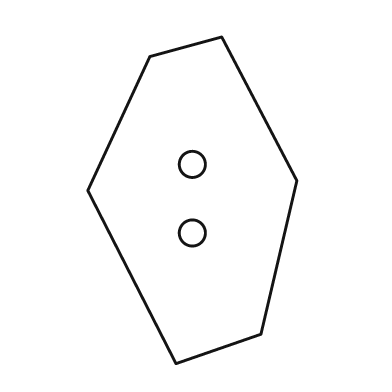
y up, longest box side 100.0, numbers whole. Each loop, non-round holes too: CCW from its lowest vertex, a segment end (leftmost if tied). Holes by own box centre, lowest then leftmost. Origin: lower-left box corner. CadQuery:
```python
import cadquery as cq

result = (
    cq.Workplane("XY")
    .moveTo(27.0, 0.0)
    .lineTo(53.0, 9.0)
    .lineTo(64.0, 56.0)
    .lineTo(41.0, 100.0)
    .lineTo(19.0, 94.0)
    .lineTo(0.0, 53.0)
    .close()
    .moveTo(32.0, 40.0)
    .circle(4.0)
    .moveTo(32.0, 61.0)
    .circle(4.0)
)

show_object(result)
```